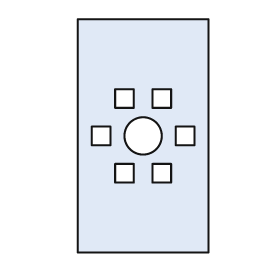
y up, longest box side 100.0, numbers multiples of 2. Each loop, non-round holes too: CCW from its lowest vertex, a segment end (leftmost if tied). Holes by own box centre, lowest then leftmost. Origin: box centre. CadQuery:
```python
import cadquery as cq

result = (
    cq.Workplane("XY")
    .moveTo(-28.0, -50.0)
    .lineTo(28.0, -50.0)
    .lineTo(28.0, 50.0)
    .lineTo(-28.0, 50.0)
    .close()
    .moveTo(-12.0, -20.0)
    .lineTo(-4.0, -20.0)
    .lineTo(-4.0, -12.0)
    .lineTo(-12.0, -12.0)
    .close()
    .moveTo(4.0, -20.0)
    .lineTo(12.0, -20.0)
    .lineTo(12.0, -12.0)
    .lineTo(4.0, -12.0)
    .close()
    .moveTo(-22.0, -4.0)
    .lineTo(-14.0, -4.0)
    .lineTo(-14.0, 4.0)
    .lineTo(-22.0, 4.0)
    .close()
    .moveTo(0.0, 0.0)
    .circle(8.0)
    .moveTo(14.0, -4.0)
    .lineTo(22.0, -4.0)
    .lineTo(22.0, 4.0)
    .lineTo(14.0, 4.0)
    .close()
    .moveTo(-12.0, 12.0)
    .lineTo(-4.0, 12.0)
    .lineTo(-4.0, 20.0)
    .lineTo(-12.0, 20.0)
    .close()
    .moveTo(4.0, 12.0)
    .lineTo(12.0, 12.0)
    .lineTo(12.0, 20.0)
    .lineTo(4.0, 20.0)
    .close()
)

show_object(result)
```